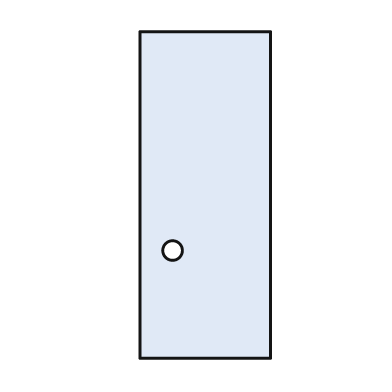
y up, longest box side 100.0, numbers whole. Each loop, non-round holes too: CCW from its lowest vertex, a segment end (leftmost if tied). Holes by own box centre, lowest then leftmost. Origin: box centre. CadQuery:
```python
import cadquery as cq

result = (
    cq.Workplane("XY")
    .moveTo(-20.0, -50.0)
    .lineTo(20.0, -50.0)
    .lineTo(20.0, 50.0)
    .lineTo(-20.0, 50.0)
    .close()
    .moveTo(-10.0, -17.0)
    .circle(3.0)
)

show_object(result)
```